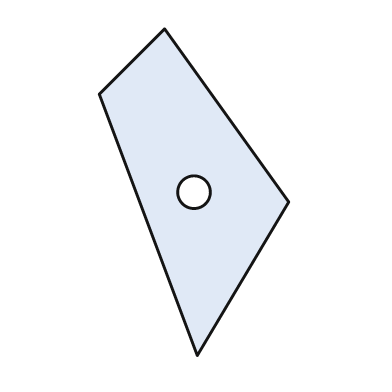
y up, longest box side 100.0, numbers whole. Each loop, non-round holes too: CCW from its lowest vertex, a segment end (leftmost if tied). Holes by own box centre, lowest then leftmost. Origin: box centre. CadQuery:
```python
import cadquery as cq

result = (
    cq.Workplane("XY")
    .moveTo(1.0, -50.0)
    .lineTo(29.0, -3.0)
    .lineTo(-9.0, 50.0)
    .lineTo(-29.0, 30.0)
    .close()
    .moveTo(0.0, 0.0)
    .circle(5.0)
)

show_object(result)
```